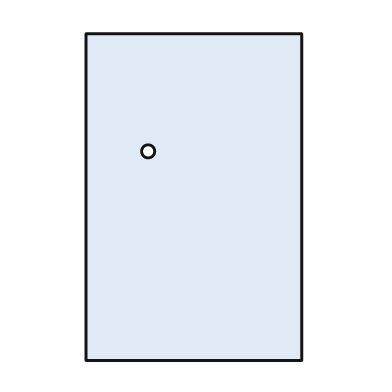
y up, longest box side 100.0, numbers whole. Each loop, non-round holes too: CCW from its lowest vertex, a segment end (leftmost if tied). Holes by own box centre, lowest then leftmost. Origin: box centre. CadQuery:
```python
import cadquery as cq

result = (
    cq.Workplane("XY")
    .moveTo(-33.0, -50.0)
    .lineTo(33.0, -50.0)
    .lineTo(33.0, 50.0)
    .lineTo(-33.0, 50.0)
    .close()
    .moveTo(-14.0, 14.0)
    .circle(2.0)
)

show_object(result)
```